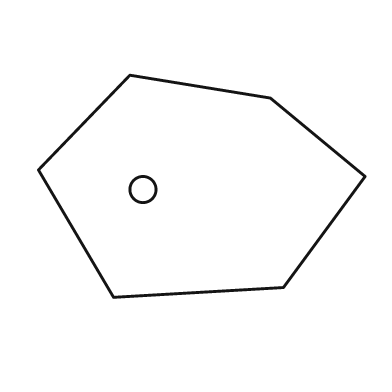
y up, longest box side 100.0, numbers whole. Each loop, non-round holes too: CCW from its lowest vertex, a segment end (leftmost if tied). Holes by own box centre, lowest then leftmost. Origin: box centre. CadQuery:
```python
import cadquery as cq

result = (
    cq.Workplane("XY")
    .moveTo(-27.0, -34.0)
    .lineTo(25.0, -31.0)
    .lineTo(50.0, 3.0)
    .lineTo(21.0, 27.0)
    .lineTo(-22.0, 34.0)
    .lineTo(-50.0, 5.0)
    .close()
    .moveTo(-18.0, -1.0)
    .circle(4.0)
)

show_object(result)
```